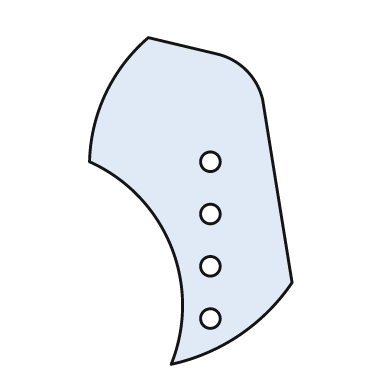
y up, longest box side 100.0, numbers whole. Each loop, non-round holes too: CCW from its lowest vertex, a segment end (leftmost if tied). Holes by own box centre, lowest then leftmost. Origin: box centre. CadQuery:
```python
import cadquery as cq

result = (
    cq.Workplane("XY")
    .moveTo(-6.0, -50.0)
    .threePointArc((15.0, -41.0), (31.0, -25.0))
    .lineTo(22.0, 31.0)
    .threePointArc((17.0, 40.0), (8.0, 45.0))
    .lineTo(-13.0, 50.0)
    .threePointArc((-26.0, 33.0), (-31.0, 12.0))
    .threePointArc((-6.0, -14.0), (-6.0, -50.0))
    .close()
    .moveTo(6.0, -36.0)
    .circle(3.0)
    .moveTo(6.0, -20.0)
    .circle(3.0)
    .moveTo(6.0, -4.0)
    .circle(3.0)
    .moveTo(6.0, 12.0)
    .circle(3.0)
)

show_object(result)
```